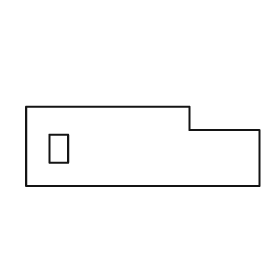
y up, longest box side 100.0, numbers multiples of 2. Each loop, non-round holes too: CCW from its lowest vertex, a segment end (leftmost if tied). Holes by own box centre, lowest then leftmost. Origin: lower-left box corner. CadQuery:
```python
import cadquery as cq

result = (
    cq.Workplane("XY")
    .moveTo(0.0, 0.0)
    .lineTo(100.0, 0.0)
    .lineTo(100.0, 24.0)
    .lineTo(70.0, 24.0)
    .lineTo(70.0, 34.0)
    .lineTo(0.0, 34.0)
    .close()
    .moveTo(10.0, 10.0)
    .lineTo(18.0, 10.0)
    .lineTo(18.0, 22.0)
    .lineTo(10.0, 22.0)
    .close()
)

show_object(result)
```